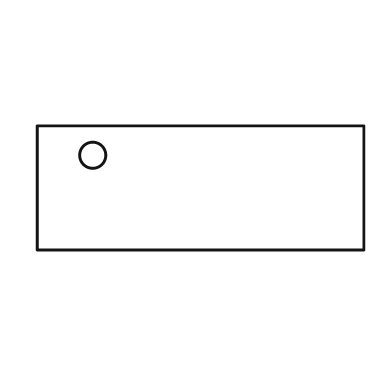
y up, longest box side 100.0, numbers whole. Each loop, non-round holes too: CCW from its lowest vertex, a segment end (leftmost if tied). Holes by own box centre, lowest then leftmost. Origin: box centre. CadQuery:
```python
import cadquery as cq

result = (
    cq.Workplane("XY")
    .moveTo(-50.0, -19.0)
    .lineTo(50.0, -19.0)
    .lineTo(50.0, 19.0)
    .lineTo(-50.0, 19.0)
    .close()
    .moveTo(-33.0, 10.0)
    .circle(4.0)
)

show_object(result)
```